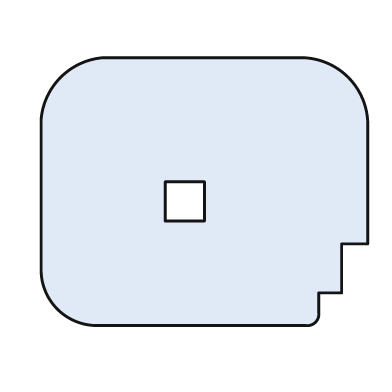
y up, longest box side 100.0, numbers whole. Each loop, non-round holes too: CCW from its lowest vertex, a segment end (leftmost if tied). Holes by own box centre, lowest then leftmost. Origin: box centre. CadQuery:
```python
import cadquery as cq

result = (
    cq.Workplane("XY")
    .moveTo(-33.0, -41.0)
    .lineTo(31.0, -41.0)
    .threePointArc((34.0, -40.0), (35.0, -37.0))
    .lineTo(35.0, -31.0)
    .lineTo(42.0, -31.0)
    .lineTo(42.0, -16.0)
    .lineTo(50.0, -16.0)
    .lineTo(50.0, 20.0)
    .threePointArc((44.0, 35.0), (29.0, 41.0))
    .lineTo(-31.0, 41.0)
    .threePointArc((-44.0, 35.0), (-50.0, 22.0))
    .lineTo(-50.0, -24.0)
    .threePointArc((-45.0, -36.0), (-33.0, -41.0))
    .close()
    .moveTo(-12.0, -9.0)
    .lineTo(0.0, -9.0)
    .lineTo(0.0, 3.0)
    .lineTo(-12.0, 3.0)
    .close()
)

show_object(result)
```